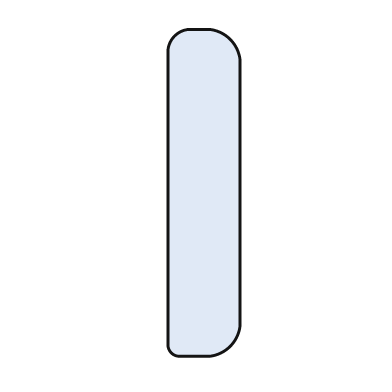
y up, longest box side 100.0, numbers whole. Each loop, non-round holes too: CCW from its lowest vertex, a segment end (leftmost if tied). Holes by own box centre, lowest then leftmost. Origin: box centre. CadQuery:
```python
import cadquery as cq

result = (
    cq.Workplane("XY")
    .moveTo(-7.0, -50.0)
    .lineTo(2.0, -50.0)
    .threePointArc((8.0, -47.0), (11.0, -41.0))
    .lineTo(11.0, 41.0)
    .threePointArc((8.0, 47.0), (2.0, 50.0))
    .lineTo(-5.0, 50.0)
    .threePointArc((-9.0, 48.0), (-11.0, 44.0))
    .lineTo(-11.0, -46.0)
    .threePointArc((-10.0, -49.0), (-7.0, -50.0))
    .close()
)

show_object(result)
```